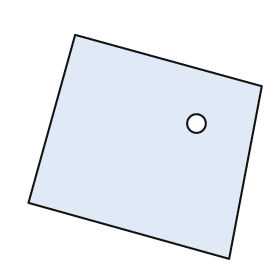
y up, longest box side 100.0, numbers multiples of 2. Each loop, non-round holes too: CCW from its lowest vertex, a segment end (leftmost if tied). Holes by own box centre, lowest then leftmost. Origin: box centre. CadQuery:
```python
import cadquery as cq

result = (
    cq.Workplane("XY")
    .moveTo(36.0, -48.0)
    .lineTo(50.0, 26.0)
    .lineTo(-30.0, 48.0)
    .lineTo(-50.0, -24.0)
    .close()
    .moveTo(22.0, 10.0)
    .circle(4.0)
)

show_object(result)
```